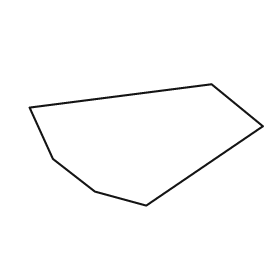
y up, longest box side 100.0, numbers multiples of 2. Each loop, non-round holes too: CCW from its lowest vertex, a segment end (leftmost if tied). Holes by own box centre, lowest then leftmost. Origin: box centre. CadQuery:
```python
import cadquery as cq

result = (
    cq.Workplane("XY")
    .moveTo(0.0, -26.0)
    .lineTo(50.0, 8.0)
    .lineTo(28.0, 26.0)
    .lineTo(-50.0, 16.0)
    .lineTo(-40.0, -6.0)
    .lineTo(-22.0, -20.0)
    .close()
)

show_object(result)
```